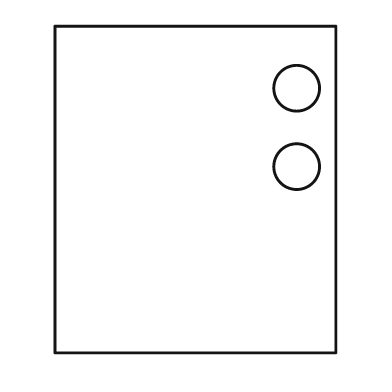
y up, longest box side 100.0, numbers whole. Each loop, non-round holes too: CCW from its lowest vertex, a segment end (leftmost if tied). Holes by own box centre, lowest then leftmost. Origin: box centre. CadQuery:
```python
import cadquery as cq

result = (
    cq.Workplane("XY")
    .moveTo(-43.0, -50.0)
    .lineTo(43.0, -50.0)
    .lineTo(43.0, 50.0)
    .lineTo(-43.0, 50.0)
    .close()
    .moveTo(31.0, 7.0)
    .circle(7.0)
    .moveTo(31.0, 31.0)
    .circle(7.0)
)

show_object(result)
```